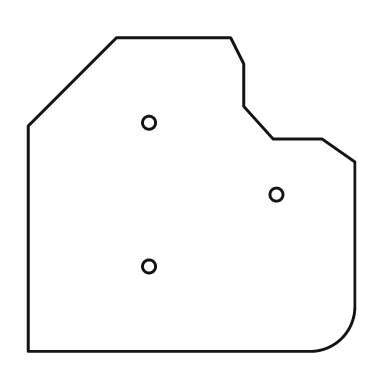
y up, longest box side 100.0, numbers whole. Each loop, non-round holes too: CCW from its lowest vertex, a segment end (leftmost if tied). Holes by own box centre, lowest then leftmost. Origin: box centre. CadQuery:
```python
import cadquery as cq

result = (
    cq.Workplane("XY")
    .moveTo(-50.0, -48.0)
    .lineTo(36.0, -48.0)
    .threePointArc((46.0, -44.0), (50.0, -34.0))
    .lineTo(50.0, 10.0)
    .lineTo(40.0, 17.0)
    .lineTo(25.0, 17.0)
    .lineTo(16.0, 27.0)
    .lineTo(16.0, 40.0)
    .lineTo(12.0, 48.0)
    .lineTo(-23.0, 48.0)
    .lineTo(-50.0, 21.0)
    .close()
    .moveTo(-13.0, -22.0)
    .circle(2.0)
    .moveTo(26.0, 0.0)
    .circle(2.0)
    .moveTo(-13.0, 22.0)
    .circle(2.0)
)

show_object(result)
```